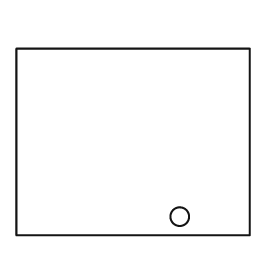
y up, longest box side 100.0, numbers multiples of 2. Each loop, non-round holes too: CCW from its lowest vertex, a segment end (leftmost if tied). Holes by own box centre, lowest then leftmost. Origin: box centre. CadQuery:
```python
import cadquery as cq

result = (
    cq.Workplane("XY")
    .moveTo(-50.0, -40.0)
    .lineTo(50.0, -40.0)
    .lineTo(50.0, 40.0)
    .lineTo(-50.0, 40.0)
    .close()
    .moveTo(20.0, -32.0)
    .circle(4.0)
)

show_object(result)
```